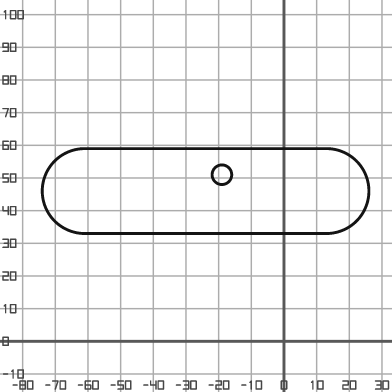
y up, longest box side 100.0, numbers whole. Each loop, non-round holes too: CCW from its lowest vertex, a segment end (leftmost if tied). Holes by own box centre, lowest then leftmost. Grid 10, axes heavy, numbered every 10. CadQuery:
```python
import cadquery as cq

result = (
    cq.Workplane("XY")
    .moveTo(-61.0, 33.0)
    .lineTo(13.0, 33.0)
    .threePointArc((26.0, 46.0), (13.0, 59.0))
    .lineTo(-61.0, 59.0)
    .threePointArc((-74.0, 46.0), (-61.0, 33.0))
    .close()
    .moveTo(-19.0, 51.0)
    .circle(3.0)
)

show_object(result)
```